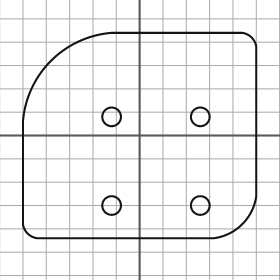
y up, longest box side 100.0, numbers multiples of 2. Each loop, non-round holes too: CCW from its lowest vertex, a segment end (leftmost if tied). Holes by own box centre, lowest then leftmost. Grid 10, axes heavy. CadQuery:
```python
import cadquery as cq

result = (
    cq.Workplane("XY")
    .moveTo(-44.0, -44.0)
    .lineTo(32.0, -44.0)
    .threePointArc((44.0, -38.0), (50.0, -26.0))
    .lineTo(50.0, 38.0)
    .threePointArc((48.0, 42.0), (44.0, 44.0))
    .lineTo(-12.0, 44.0)
    .threePointArc((-38.0, 32.0), (-50.0, 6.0))
    .lineTo(-50.0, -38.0)
    .threePointArc((-48.0, -42.0), (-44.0, -44.0))
    .close()
    .moveTo(-12.0, -30.0)
    .circle(4.0)
    .moveTo(26.0, -30.0)
    .circle(4.0)
    .moveTo(-12.0, 8.0)
    .circle(4.0)
    .moveTo(26.0, 8.0)
    .circle(4.0)
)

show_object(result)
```